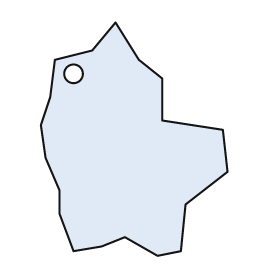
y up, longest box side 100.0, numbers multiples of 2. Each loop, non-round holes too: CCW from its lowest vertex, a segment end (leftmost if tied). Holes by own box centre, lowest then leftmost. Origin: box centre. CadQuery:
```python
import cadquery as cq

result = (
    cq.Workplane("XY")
    .moveTo(10.0, -50.0)
    .lineTo(20.0, -48.0)
    .lineTo(22.0, -28.0)
    .lineTo(40.0, -14.0)
    .lineTo(38.0, 4.0)
    .lineTo(12.0, 8.0)
    .lineTo(12.0, 26.0)
    .lineTo(2.0, 34.0)
    .lineTo(-8.0, 50.0)
    .lineTo(-18.0, 38.0)
    .lineTo(-34.0, 34.0)
    .lineTo(-36.0, 18.0)
    .lineTo(-40.0, 6.0)
    .lineTo(-38.0, -8.0)
    .lineTo(-32.0, -22.0)
    .lineTo(-32.0, -32.0)
    .lineTo(-26.0, -48.0)
    .lineTo(-14.0, -46.0)
    .lineTo(-4.0, -42.0)
    .close()
    .moveTo(-26.0, 28.0)
    .circle(4.0)
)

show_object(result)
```